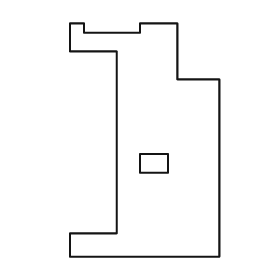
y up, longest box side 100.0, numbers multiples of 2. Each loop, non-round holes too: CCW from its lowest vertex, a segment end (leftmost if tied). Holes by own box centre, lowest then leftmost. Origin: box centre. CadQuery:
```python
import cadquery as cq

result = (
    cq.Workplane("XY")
    .moveTo(-32.0, -50.0)
    .lineTo(32.0, -50.0)
    .lineTo(32.0, 26.0)
    .lineTo(14.0, 26.0)
    .lineTo(14.0, 50.0)
    .lineTo(-2.0, 50.0)
    .lineTo(-2.0, 46.0)
    .lineTo(-26.0, 46.0)
    .lineTo(-26.0, 50.0)
    .lineTo(-32.0, 50.0)
    .lineTo(-32.0, 38.0)
    .lineTo(-12.0, 38.0)
    .lineTo(-12.0, -40.0)
    .lineTo(-32.0, -40.0)
    .close()
    .moveTo(-2.0, -14.0)
    .lineTo(10.0, -14.0)
    .lineTo(10.0, -6.0)
    .lineTo(-2.0, -6.0)
    .close()
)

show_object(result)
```